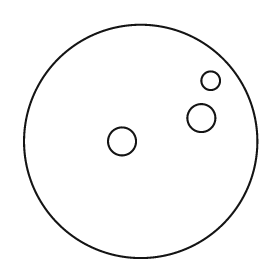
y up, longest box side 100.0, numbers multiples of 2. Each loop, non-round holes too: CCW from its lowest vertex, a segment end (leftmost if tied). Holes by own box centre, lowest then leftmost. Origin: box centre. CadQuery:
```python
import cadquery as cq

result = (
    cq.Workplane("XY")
    .moveTo(0.0, 0.0)
    .circle(50.0)
    .moveTo(-8.0, 0.0)
    .circle(6.0)
    .moveTo(26.0, 10.0)
    .circle(6.0)
    .moveTo(30.0, 26.0)
    .circle(4.0)
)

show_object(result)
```